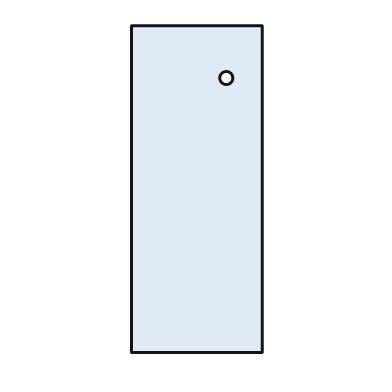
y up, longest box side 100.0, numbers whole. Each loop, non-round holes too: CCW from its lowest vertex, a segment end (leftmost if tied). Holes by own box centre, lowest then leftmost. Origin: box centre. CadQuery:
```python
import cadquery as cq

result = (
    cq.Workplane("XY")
    .moveTo(-20.0, -50.0)
    .lineTo(20.0, -50.0)
    .lineTo(20.0, 50.0)
    .lineTo(-20.0, 50.0)
    .close()
    .moveTo(9.0, 34.0)
    .circle(2.0)
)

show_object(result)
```